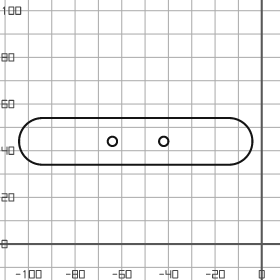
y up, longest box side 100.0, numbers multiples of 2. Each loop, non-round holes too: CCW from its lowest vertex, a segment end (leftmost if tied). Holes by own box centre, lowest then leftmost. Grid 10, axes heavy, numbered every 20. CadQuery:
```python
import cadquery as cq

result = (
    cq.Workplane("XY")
    .moveTo(-94.0, 34.0)
    .lineTo(-14.0, 34.0)
    .threePointArc((-4.0, 44.0), (-14.0, 54.0))
    .lineTo(-94.0, 54.0)
    .threePointArc((-104.0, 44.0), (-94.0, 34.0))
    .close()
    .moveTo(-64.0, 44.0)
    .circle(2.0)
    .moveTo(-42.0, 44.0)
    .circle(2.0)
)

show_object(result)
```